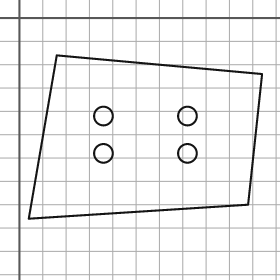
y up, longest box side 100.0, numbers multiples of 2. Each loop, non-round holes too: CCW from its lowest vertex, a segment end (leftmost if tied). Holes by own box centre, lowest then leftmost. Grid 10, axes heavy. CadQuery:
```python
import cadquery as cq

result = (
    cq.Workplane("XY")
    .moveTo(4.0, -86.0)
    .lineTo(98.0, -80.0)
    .lineTo(104.0, -24.0)
    .lineTo(16.0, -16.0)
    .close()
    .moveTo(36.0, -58.0)
    .circle(4.0)
    .moveTo(72.0, -58.0)
    .circle(4.0)
    .moveTo(36.0, -42.0)
    .circle(4.0)
    .moveTo(72.0, -42.0)
    .circle(4.0)
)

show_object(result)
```